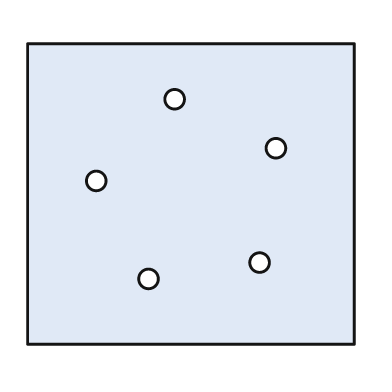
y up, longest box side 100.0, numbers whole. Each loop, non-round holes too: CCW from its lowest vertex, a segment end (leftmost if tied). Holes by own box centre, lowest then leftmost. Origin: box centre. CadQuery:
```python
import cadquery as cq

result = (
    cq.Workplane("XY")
    .moveTo(-50.0, -46.0)
    .lineTo(50.0, -46.0)
    .lineTo(50.0, 46.0)
    .lineTo(-50.0, 46.0)
    .close()
    .moveTo(-13.0, -26.0)
    .circle(3.0)
    .moveTo(21.0, -21.0)
    .circle(3.0)
    .moveTo(-29.0, 4.0)
    .circle(3.0)
    .moveTo(26.0, 14.0)
    .circle(3.0)
    .moveTo(-5.0, 29.0)
    .circle(3.0)
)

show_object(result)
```